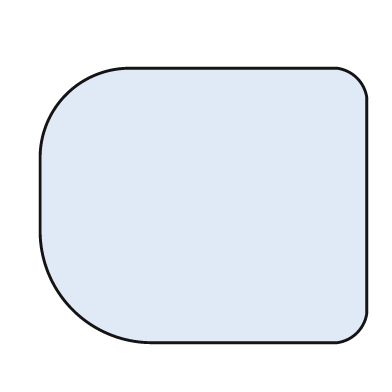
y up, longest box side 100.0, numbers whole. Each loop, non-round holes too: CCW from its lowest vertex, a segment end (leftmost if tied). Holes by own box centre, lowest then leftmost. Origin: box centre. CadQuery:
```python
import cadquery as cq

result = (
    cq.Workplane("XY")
    .moveTo(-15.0, -42.0)
    .lineTo(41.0, -42.0)
    .threePointArc((47.0, -39.0), (50.0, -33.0))
    .lineTo(50.0, 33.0)
    .threePointArc((47.0, 39.0), (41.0, 42.0))
    .lineTo(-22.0, 42.0)
    .threePointArc((-42.0, 34.0), (-50.0, 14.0))
    .lineTo(-50.0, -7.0)
    .threePointArc((-40.0, -32.0), (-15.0, -42.0))
    .close()
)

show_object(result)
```